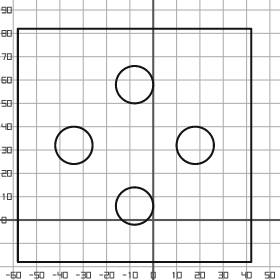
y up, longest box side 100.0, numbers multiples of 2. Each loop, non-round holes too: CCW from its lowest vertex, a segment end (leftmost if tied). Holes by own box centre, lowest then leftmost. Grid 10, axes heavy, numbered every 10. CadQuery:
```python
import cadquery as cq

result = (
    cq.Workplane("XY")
    .moveTo(-58.0, -18.0)
    .lineTo(42.0, -18.0)
    .lineTo(42.0, 82.0)
    .lineTo(-58.0, 82.0)
    .close()
    .moveTo(-8.0, 6.0)
    .circle(8.0)
    .moveTo(-34.0, 32.0)
    .circle(8.0)
    .moveTo(18.0, 32.0)
    .circle(8.0)
    .moveTo(-8.0, 58.0)
    .circle(8.0)
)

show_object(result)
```